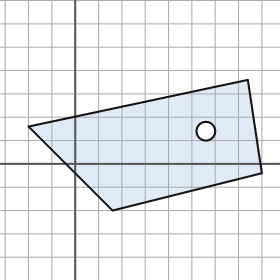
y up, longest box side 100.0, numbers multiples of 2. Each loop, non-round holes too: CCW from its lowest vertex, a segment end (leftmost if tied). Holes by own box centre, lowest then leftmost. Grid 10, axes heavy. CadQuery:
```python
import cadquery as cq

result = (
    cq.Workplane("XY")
    .moveTo(16.0, -20.0)
    .lineTo(80.0, -4.0)
    .lineTo(74.0, 36.0)
    .lineTo(-20.0, 16.0)
    .close()
    .moveTo(56.0, 14.0)
    .circle(4.0)
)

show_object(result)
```